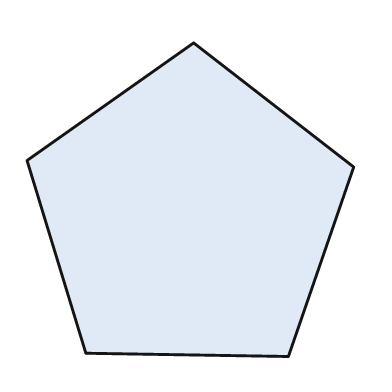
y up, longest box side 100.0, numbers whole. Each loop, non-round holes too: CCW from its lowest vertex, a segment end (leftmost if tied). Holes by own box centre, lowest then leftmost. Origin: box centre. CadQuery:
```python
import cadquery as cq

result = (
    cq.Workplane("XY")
    .moveTo(30.0, -48.0)
    .lineTo(50.0, 10.0)
    .lineTo(1.0, 48.0)
    .lineTo(-50.0, 12.0)
    .lineTo(-32.0, -47.0)
    .close()
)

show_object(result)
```